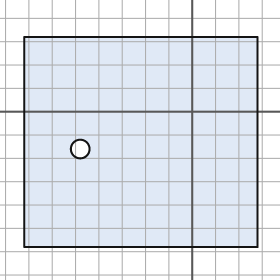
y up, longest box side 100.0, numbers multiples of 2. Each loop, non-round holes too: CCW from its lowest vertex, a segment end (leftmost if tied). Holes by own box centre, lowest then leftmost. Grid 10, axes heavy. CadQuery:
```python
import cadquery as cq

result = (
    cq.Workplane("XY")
    .moveTo(-72.0, -58.0)
    .lineTo(28.0, -58.0)
    .lineTo(28.0, 32.0)
    .lineTo(-72.0, 32.0)
    .close()
    .moveTo(-48.0, -16.0)
    .circle(4.0)
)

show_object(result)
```